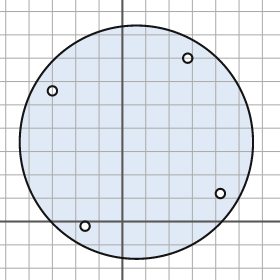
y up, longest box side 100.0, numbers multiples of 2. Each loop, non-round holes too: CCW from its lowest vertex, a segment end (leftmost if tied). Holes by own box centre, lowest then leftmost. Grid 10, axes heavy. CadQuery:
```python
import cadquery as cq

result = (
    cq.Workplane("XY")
    .moveTo(6.0, 34.0)
    .circle(50.0)
    .moveTo(-16.0, -2.0)
    .circle(2.0)
    .moveTo(42.0, 12.0)
    .circle(2.0)
    .moveTo(-30.0, 56.0)
    .circle(2.0)
    .moveTo(28.0, 70.0)
    .circle(2.0)
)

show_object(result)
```